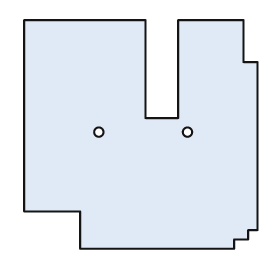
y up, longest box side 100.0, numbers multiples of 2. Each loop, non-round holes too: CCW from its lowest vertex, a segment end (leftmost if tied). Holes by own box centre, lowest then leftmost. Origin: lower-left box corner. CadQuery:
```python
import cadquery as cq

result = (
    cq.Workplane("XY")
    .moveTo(24.0, 0.0)
    .lineTo(90.0, 0.0)
    .lineTo(90.0, 4.0)
    .lineTo(96.0, 4.0)
    .lineTo(96.0, 8.0)
    .lineTo(100.0, 8.0)
    .lineTo(100.0, 80.0)
    .lineTo(94.0, 80.0)
    .lineTo(94.0, 98.0)
    .lineTo(66.0, 98.0)
    .lineTo(66.0, 56.0)
    .lineTo(52.0, 56.0)
    .lineTo(52.0, 98.0)
    .lineTo(0.0, 98.0)
    .lineTo(0.0, 16.0)
    .lineTo(24.0, 16.0)
    .close()
    .moveTo(32.0, 50.0)
    .circle(2.0)
    .moveTo(70.0, 50.0)
    .circle(2.0)
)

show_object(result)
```